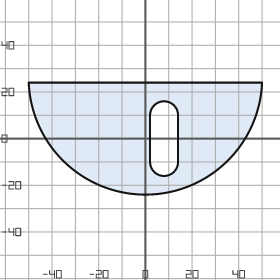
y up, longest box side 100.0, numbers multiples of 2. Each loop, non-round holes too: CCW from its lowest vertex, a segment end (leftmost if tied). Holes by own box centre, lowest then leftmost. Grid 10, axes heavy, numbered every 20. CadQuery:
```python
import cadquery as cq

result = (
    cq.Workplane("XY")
    .moveTo(-50.0, 24.0)
    .threePointArc((0.0, -24.0), (50.0, 24.0))
    .close()
    .moveTo(2.0, -10.0)
    .threePointArc((8.0, -16.0), (14.0, -10.0))
    .lineTo(14.0, 10.0)
    .threePointArc((8.0, 16.0), (2.0, 10.0))
    .close()
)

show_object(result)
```